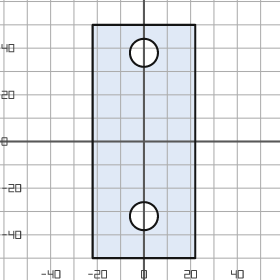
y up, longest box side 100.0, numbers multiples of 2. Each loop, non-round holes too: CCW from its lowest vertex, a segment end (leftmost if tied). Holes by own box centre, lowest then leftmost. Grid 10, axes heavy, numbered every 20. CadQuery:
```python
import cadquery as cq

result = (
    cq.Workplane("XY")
    .moveTo(-22.0, -50.0)
    .lineTo(22.0, -50.0)
    .lineTo(22.0, 50.0)
    .lineTo(-22.0, 50.0)
    .close()
    .moveTo(0.0, -32.0)
    .circle(6.0)
    .moveTo(0.0, 38.0)
    .circle(6.0)
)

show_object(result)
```